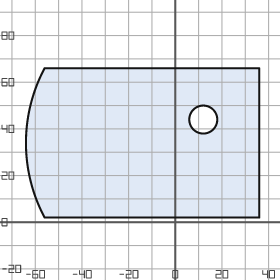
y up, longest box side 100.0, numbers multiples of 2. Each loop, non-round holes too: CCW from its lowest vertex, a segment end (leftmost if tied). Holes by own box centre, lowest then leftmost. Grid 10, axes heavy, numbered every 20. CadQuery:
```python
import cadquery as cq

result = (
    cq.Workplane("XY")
    .moveTo(-56.0, 2.0)
    .lineTo(36.0, 2.0)
    .lineTo(36.0, 66.0)
    .lineTo(-56.0, 66.0)
    .threePointArc((-64.0, 34.0), (-56.0, 2.0))
    .close()
    .moveTo(12.0, 44.0)
    .circle(6.0)
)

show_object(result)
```